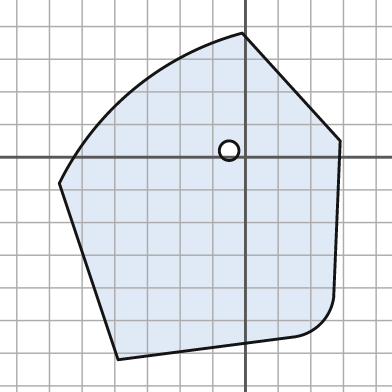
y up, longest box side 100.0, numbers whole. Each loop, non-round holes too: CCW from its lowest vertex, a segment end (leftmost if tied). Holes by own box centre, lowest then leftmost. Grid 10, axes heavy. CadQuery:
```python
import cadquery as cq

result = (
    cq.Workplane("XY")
    .moveTo(-39.0, -62.0)
    .lineTo(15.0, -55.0)
    .threePointArc((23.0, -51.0), (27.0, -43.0))
    .lineTo(29.0, 5.0)
    .lineTo(-1.0, 38.0)
    .threePointArc((-34.0, 21.0), (-57.0, -8.0))
    .close()
    .moveTo(-5.0, 2.0)
    .circle(3.0)
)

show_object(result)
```